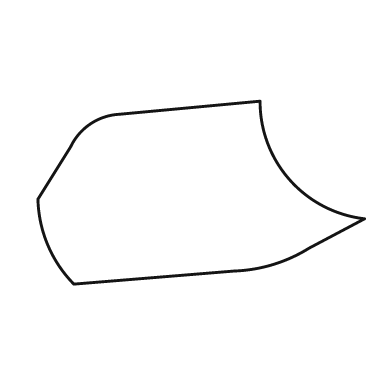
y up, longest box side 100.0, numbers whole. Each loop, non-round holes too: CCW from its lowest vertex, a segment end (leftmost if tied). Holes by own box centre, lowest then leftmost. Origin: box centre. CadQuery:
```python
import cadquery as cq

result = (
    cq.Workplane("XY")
    .moveTo(-39.0, -28.0)
    .lineTo(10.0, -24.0)
    .threePointArc((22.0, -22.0), (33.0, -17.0))
    .lineTo(50.0, -8.0)
    .threePointArc((27.0, 4.0), (18.0, 28.0))
    .lineTo(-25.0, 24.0)
    .threePointArc((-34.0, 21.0), (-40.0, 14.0))
    .lineTo(-50.0, -2.0)
    .threePointArc((-47.0, -16.0), (-39.0, -28.0))
    .close()
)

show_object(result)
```